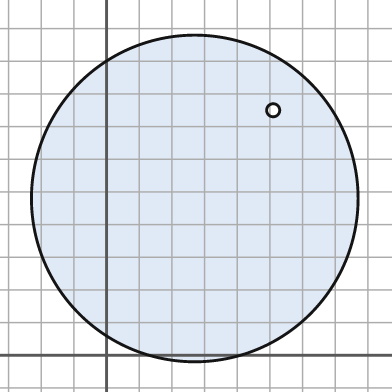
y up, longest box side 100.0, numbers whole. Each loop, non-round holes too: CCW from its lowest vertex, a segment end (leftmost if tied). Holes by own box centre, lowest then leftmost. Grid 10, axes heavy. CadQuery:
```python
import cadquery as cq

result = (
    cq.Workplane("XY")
    .moveTo(27.0, 48.0)
    .circle(50.0)
    .moveTo(51.0, 75.0)
    .circle(2.0)
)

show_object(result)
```